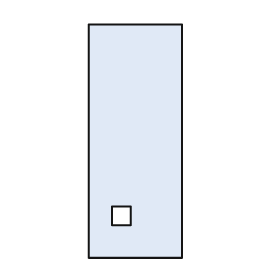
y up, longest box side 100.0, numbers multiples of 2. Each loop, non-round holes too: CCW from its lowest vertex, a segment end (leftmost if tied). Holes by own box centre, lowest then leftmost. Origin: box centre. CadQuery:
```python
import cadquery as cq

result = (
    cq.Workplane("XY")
    .moveTo(-20.0, -50.0)
    .lineTo(20.0, -50.0)
    .lineTo(20.0, 50.0)
    .lineTo(-20.0, 50.0)
    .close()
    .moveTo(-10.0, -36.0)
    .lineTo(-2.0, -36.0)
    .lineTo(-2.0, -28.0)
    .lineTo(-10.0, -28.0)
    .close()
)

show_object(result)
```